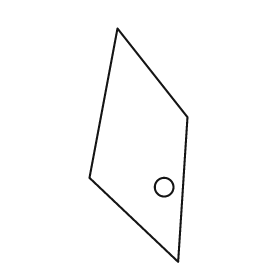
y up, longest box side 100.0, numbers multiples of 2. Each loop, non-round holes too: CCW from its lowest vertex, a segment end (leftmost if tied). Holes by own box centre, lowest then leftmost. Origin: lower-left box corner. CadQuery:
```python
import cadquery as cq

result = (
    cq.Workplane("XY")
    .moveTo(38.0, 0.0)
    .lineTo(42.0, 62.0)
    .lineTo(12.0, 100.0)
    .lineTo(0.0, 36.0)
    .close()
    .moveTo(32.0, 32.0)
    .circle(4.0)
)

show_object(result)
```